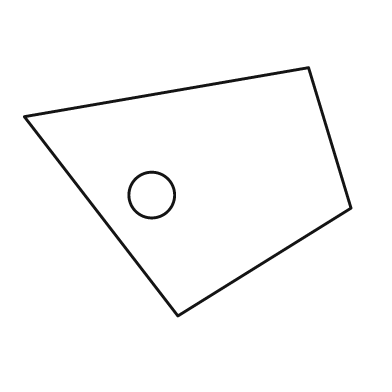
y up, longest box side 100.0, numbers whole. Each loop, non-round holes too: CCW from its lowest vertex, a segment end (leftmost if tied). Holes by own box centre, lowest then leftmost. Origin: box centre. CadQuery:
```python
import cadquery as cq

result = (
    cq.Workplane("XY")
    .moveTo(-3.0, -38.0)
    .lineTo(50.0, -5.0)
    .lineTo(37.0, 38.0)
    .lineTo(-50.0, 23.0)
    .close()
    .moveTo(-11.0, -1.0)
    .circle(7.0)
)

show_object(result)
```